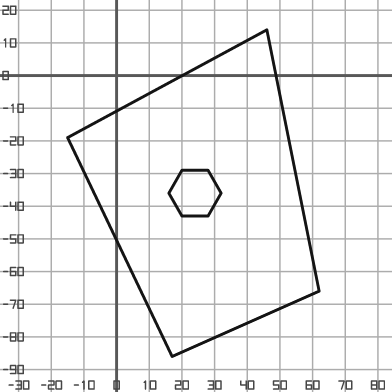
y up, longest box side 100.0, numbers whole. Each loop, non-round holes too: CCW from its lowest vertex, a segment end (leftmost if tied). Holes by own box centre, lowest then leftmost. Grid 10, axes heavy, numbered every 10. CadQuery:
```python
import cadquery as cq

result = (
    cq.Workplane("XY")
    .moveTo(17.0, -86.0)
    .lineTo(62.0, -66.0)
    .lineTo(46.0, 14.0)
    .lineTo(-15.0, -19.0)
    .close()
    .moveTo(20.0, -43.0)
    .lineTo(28.0, -43.0)
    .lineTo(32.0, -36.0)
    .lineTo(28.0, -29.0)
    .lineTo(20.0, -29.0)
    .lineTo(16.0, -36.0)
    .close()
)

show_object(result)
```